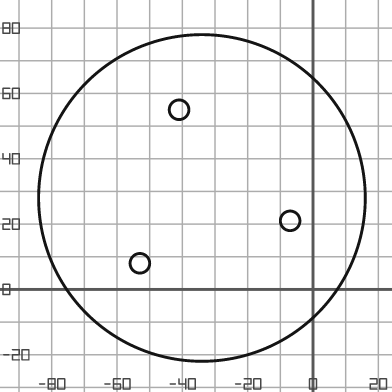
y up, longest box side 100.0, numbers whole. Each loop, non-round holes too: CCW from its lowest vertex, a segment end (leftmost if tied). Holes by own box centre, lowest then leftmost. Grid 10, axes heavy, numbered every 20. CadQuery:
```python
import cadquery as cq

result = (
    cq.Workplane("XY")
    .moveTo(-34.0, 28.0)
    .circle(50.0)
    .moveTo(-53.0, 8.0)
    .circle(3.0)
    .moveTo(-7.0, 21.0)
    .circle(3.0)
    .moveTo(-41.0, 55.0)
    .circle(3.0)
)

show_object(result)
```